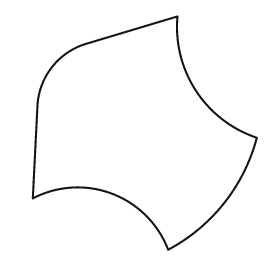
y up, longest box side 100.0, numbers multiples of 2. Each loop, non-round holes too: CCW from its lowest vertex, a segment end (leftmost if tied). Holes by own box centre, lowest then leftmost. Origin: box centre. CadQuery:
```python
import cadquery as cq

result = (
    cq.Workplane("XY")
    .moveTo(10.0, -50.0)
    .threePointArc((34.0, -30.0), (48.0, -2.0))
    .threePointArc((22.0, 18.0), (14.0, 50.0))
    .lineTo(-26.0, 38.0)
    .threePointArc((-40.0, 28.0), (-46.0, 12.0))
    .lineTo(-48.0, -28.0)
    .threePointArc((-14.0, -26.0), (10.0, -50.0))
    .close()
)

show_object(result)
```